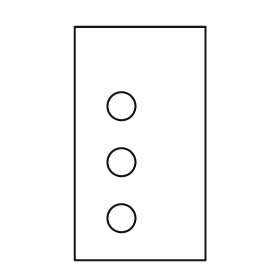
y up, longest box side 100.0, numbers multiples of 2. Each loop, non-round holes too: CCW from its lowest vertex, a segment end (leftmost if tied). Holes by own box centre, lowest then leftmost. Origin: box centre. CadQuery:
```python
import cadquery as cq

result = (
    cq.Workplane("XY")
    .moveTo(-28.0, -50.0)
    .lineTo(28.0, -50.0)
    .lineTo(28.0, 50.0)
    .lineTo(-28.0, 50.0)
    .close()
    .moveTo(-8.0, -32.0)
    .circle(6.0)
    .moveTo(-8.0, -8.0)
    .circle(6.0)
    .moveTo(-8.0, 16.0)
    .circle(6.0)
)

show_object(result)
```